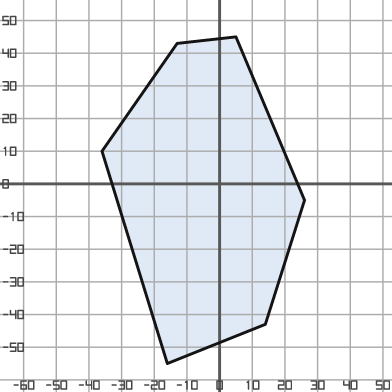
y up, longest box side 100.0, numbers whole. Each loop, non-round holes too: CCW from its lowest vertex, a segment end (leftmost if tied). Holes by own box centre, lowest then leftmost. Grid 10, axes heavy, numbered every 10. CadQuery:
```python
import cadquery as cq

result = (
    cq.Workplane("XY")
    .moveTo(-16.0, -55.0)
    .lineTo(14.0, -43.0)
    .lineTo(26.0, -5.0)
    .lineTo(5.0, 45.0)
    .lineTo(-13.0, 43.0)
    .lineTo(-36.0, 10.0)
    .close()
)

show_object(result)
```